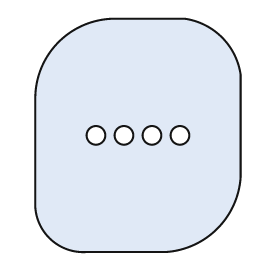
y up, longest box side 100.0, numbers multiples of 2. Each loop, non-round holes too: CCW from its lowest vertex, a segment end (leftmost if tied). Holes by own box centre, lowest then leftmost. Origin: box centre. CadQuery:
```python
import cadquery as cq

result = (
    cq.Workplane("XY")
    .moveTo(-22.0, -50.0)
    .lineTo(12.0, -50.0)
    .threePointArc((34.0, -40.0), (44.0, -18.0))
    .lineTo(44.0, 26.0)
    .threePointArc((36.0, 42.0), (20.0, 50.0))
    .lineTo(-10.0, 50.0)
    .threePointArc((-34.0, 40.0), (-44.0, 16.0))
    .lineTo(-44.0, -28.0)
    .threePointArc((-38.0, -44.0), (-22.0, -50.0))
    .close()
    .moveTo(-18.0, 0.0)
    .circle(4.0)
    .moveTo(-6.0, 0.0)
    .circle(4.0)
    .moveTo(6.0, 0.0)
    .circle(4.0)
    .moveTo(18.0, 0.0)
    .circle(4.0)
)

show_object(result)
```